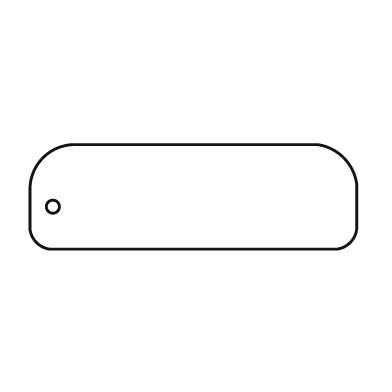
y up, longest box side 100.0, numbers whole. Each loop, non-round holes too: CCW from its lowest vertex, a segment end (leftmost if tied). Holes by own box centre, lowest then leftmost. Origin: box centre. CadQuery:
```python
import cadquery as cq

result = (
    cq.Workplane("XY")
    .moveTo(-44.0, -16.0)
    .lineTo(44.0, -16.0)
    .threePointArc((48.0, -14.0), (50.0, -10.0))
    .lineTo(50.0, 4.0)
    .threePointArc((46.0, 12.0), (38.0, 16.0))
    .lineTo(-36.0, 16.0)
    .threePointArc((-46.0, 12.0), (-50.0, 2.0))
    .lineTo(-50.0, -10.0)
    .threePointArc((-48.0, -14.0), (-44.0, -16.0))
    .close()
    .moveTo(-43.0, -3.0)
    .circle(2.0)
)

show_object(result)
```